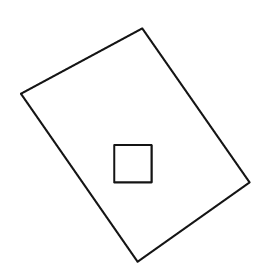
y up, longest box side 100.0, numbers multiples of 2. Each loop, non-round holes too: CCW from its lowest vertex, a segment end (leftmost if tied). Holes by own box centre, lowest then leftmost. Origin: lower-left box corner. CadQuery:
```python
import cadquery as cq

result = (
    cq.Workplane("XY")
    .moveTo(50.0, 0.0)
    .lineTo(98.0, 34.0)
    .lineTo(52.0, 100.0)
    .lineTo(0.0, 72.0)
    .close()
    .moveTo(40.0, 34.0)
    .lineTo(56.0, 34.0)
    .lineTo(56.0, 50.0)
    .lineTo(40.0, 50.0)
    .close()
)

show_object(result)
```